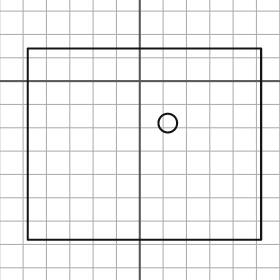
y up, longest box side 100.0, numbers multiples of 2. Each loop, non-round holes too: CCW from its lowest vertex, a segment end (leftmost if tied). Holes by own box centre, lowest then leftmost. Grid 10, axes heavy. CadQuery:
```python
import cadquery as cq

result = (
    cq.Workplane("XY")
    .moveTo(-48.0, -68.0)
    .lineTo(52.0, -68.0)
    .lineTo(52.0, 14.0)
    .lineTo(-48.0, 14.0)
    .close()
    .moveTo(12.0, -18.0)
    .circle(4.0)
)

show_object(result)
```